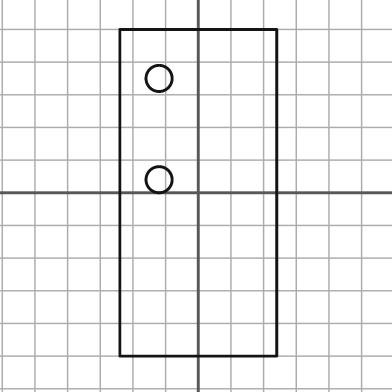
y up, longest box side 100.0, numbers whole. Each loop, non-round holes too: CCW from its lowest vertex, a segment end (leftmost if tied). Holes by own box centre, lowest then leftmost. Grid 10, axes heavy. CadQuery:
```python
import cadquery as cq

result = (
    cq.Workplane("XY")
    .moveTo(-24.0, -50.0)
    .lineTo(24.0, -50.0)
    .lineTo(24.0, 50.0)
    .lineTo(-24.0, 50.0)
    .close()
    .moveTo(-12.0, 4.0)
    .circle(4.0)
    .moveTo(-12.0, 35.0)
    .circle(4.0)
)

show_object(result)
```